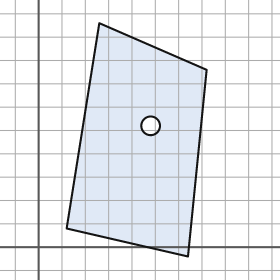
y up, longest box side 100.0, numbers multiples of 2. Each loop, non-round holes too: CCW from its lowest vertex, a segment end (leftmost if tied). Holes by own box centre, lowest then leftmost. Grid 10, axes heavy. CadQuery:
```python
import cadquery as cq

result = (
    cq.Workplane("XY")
    .moveTo(64.0, -4.0)
    .lineTo(72.0, 76.0)
    .lineTo(26.0, 96.0)
    .lineTo(12.0, 8.0)
    .close()
    .moveTo(48.0, 52.0)
    .circle(4.0)
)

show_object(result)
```